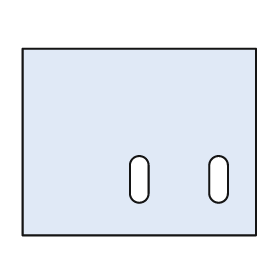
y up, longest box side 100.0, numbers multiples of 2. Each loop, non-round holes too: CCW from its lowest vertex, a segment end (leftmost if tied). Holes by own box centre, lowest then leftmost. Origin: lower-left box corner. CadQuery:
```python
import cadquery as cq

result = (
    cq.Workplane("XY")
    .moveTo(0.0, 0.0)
    .lineTo(100.0, 0.0)
    .lineTo(100.0, 80.0)
    .lineTo(0.0, 80.0)
    .close()
    .moveTo(46.0, 18.0)
    .threePointArc((50.0, 14.0), (54.0, 18.0))
    .lineTo(54.0, 30.0)
    .threePointArc((50.0, 34.0), (46.0, 30.0))
    .close()
    .moveTo(80.0, 18.0)
    .threePointArc((84.0, 14.0), (88.0, 18.0))
    .lineTo(88.0, 30.0)
    .threePointArc((84.0, 34.0), (80.0, 30.0))
    .close()
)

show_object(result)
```